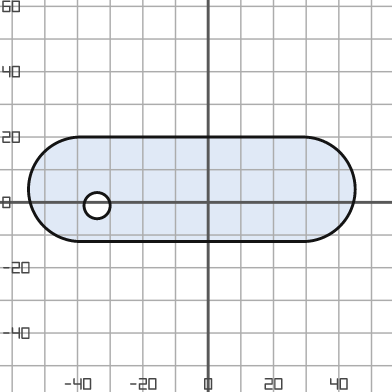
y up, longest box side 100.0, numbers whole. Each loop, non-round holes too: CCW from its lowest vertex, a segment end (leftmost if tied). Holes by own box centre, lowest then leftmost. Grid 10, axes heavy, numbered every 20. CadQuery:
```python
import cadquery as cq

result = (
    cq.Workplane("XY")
    .moveTo(-39.0, -12.0)
    .lineTo(29.0, -12.0)
    .threePointArc((45.0, 4.0), (29.0, 20.0))
    .lineTo(-39.0, 20.0)
    .threePointArc((-55.0, 4.0), (-39.0, -12.0))
    .close()
    .moveTo(-34.0, -1.0)
    .circle(4.0)
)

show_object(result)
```